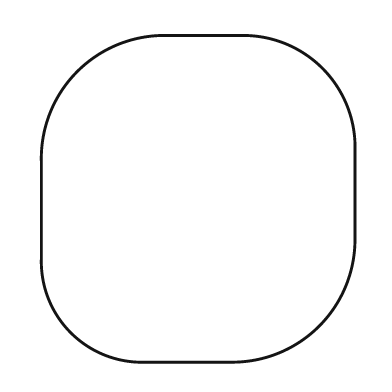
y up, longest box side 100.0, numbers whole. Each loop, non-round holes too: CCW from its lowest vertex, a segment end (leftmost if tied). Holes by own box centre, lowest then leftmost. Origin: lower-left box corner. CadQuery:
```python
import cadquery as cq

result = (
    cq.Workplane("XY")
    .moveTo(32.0, 0.0)
    .lineTo(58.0, 0.0)
    .threePointArc((85.0, 11.0), (96.0, 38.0))
    .lineTo(96.0, 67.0)
    .threePointArc((86.0, 90.0), (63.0, 100.0))
    .lineTo(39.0, 100.0)
    .threePointArc((11.0, 89.0), (0.0, 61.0))
    .lineTo(0.0, 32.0)
    .threePointArc((9.0, 9.0), (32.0, 0.0))
    .close()
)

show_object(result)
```